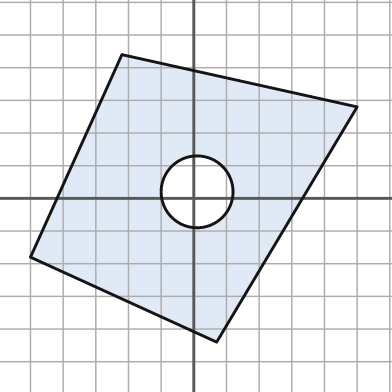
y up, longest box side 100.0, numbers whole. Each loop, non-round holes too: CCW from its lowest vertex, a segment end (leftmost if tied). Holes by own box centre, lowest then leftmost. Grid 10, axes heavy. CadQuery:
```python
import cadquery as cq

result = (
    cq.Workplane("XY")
    .moveTo(7.0, -44.0)
    .lineTo(50.0, 28.0)
    .lineTo(-22.0, 44.0)
    .lineTo(-50.0, -18.0)
    .close()
    .moveTo(1.0, 2.0)
    .circle(11.0)
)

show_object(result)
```